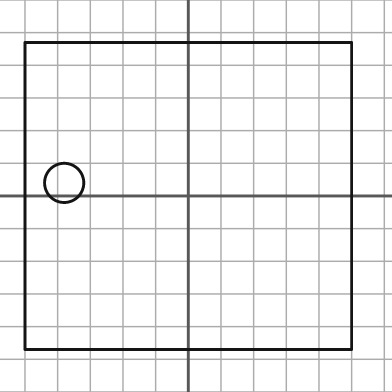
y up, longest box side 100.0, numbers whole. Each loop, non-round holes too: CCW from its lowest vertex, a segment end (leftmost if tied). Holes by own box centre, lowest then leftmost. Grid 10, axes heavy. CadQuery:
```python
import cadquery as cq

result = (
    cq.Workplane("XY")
    .moveTo(-50.0, -47.0)
    .lineTo(50.0, -47.0)
    .lineTo(50.0, 47.0)
    .lineTo(-50.0, 47.0)
    .close()
    .moveTo(-38.0, 4.0)
    .circle(6.0)
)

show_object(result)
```